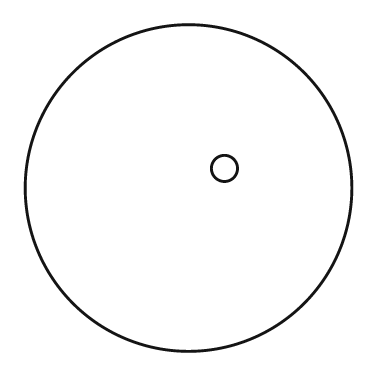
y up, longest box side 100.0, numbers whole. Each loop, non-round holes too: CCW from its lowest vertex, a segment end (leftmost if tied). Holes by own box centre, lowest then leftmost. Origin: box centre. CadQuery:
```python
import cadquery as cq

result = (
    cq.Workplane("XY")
    .moveTo(0.0, 0.0)
    .circle(50.0)
    .moveTo(11.0, 6.0)
    .circle(4.0)
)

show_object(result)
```